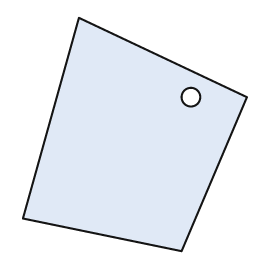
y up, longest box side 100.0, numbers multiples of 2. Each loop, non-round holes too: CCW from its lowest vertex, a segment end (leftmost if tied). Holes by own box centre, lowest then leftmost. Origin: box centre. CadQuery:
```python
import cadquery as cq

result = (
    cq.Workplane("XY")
    .moveTo(20.0, -50.0)
    .lineTo(48.0, 16.0)
    .lineTo(-24.0, 50.0)
    .lineTo(-48.0, -36.0)
    .close()
    .moveTo(24.0, 16.0)
    .circle(4.0)
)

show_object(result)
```